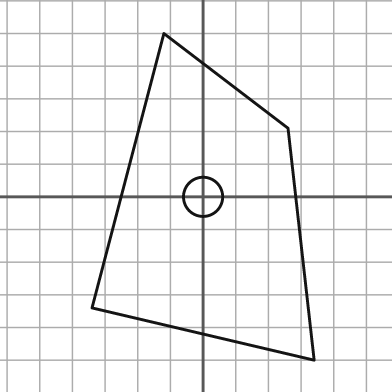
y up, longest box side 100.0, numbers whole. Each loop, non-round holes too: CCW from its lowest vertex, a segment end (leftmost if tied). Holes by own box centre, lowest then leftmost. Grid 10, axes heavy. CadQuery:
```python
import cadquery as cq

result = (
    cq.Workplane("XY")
    .moveTo(34.0, -50.0)
    .lineTo(26.0, 21.0)
    .lineTo(-12.0, 50.0)
    .lineTo(-34.0, -34.0)
    .close()
    .moveTo(0.0, 0.0)
    .circle(6.0)
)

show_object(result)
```